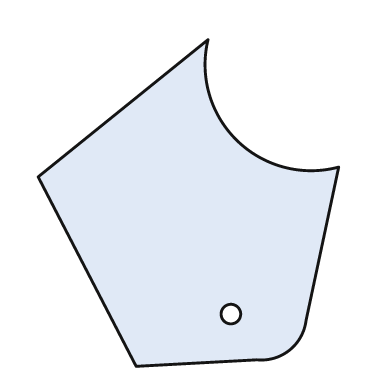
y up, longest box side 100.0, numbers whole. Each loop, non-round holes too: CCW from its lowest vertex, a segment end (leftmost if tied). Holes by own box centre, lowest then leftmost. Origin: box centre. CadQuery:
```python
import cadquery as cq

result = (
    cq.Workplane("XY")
    .moveTo(-16.0, -50.0)
    .lineTo(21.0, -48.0)
    .threePointArc((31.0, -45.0), (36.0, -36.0))
    .lineTo(46.0, 11.0)
    .threePointArc((15.0, 19.0), (6.0, 50.0))
    .lineTo(-46.0, 8.0)
    .close()
    .moveTo(13.0, -34.0)
    .circle(3.0)
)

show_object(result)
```